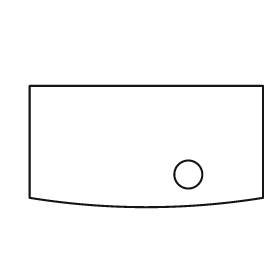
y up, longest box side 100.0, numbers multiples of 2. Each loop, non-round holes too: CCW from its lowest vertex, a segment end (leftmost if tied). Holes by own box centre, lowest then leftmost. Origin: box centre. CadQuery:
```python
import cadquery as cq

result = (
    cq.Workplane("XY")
    .moveTo(-50.0, -22.0)
    .threePointArc((0.0, -26.0), (50.0, -22.0))
    .lineTo(50.0, 26.0)
    .lineTo(-50.0, 26.0)
    .close()
    .moveTo(18.0, -12.0)
    .circle(6.0)
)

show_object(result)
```